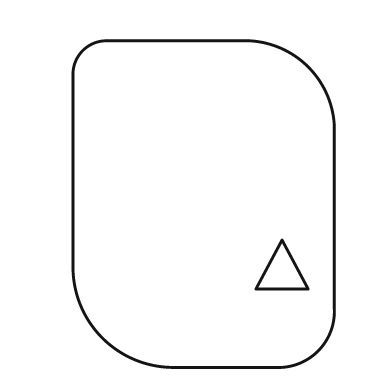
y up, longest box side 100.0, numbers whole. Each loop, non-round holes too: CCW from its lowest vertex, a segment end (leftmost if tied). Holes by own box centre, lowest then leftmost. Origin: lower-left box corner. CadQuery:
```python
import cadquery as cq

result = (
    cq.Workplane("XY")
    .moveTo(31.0, 0.0)
    .lineTo(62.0, 0.0)
    .threePointArc((75.0, 5.0), (80.0, 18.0))
    .lineTo(80.0, 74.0)
    .threePointArc((72.0, 92.0), (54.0, 100.0))
    .lineTo(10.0, 100.0)
    .threePointArc((3.0, 97.0), (0.0, 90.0))
    .lineTo(0.0, 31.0)
    .threePointArc((9.0, 9.0), (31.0, 0.0))
    .close()
    .moveTo(56.0, 24.0)
    .lineTo(72.0, 24.0)
    .lineTo(64.0, 39.0)
    .close()
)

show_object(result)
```